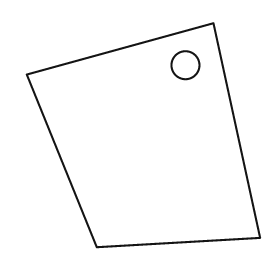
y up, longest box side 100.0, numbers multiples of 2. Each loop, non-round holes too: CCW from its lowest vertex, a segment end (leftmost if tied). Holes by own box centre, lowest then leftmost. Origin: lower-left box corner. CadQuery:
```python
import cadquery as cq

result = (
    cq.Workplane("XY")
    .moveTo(30.0, 0.0)
    .lineTo(100.0, 4.0)
    .lineTo(80.0, 96.0)
    .lineTo(0.0, 74.0)
    .close()
    .moveTo(68.0, 78.0)
    .circle(6.0)
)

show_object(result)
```